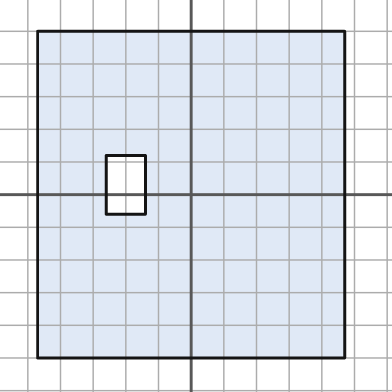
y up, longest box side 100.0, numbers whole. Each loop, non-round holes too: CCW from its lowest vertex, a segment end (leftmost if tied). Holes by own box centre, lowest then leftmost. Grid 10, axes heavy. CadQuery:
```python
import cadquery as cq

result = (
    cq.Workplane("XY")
    .moveTo(-47.0, -50.0)
    .lineTo(47.0, -50.0)
    .lineTo(47.0, 50.0)
    .lineTo(-47.0, 50.0)
    .close()
    .moveTo(-26.0, -6.0)
    .lineTo(-14.0, -6.0)
    .lineTo(-14.0, 12.0)
    .lineTo(-26.0, 12.0)
    .close()
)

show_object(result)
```